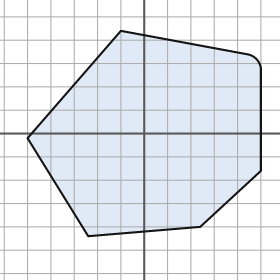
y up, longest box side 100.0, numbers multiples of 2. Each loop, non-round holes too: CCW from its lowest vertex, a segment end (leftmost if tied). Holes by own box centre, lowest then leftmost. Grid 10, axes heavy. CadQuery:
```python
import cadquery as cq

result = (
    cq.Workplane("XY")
    .moveTo(-24.0, -44.0)
    .lineTo(24.0, -40.0)
    .lineTo(50.0, -16.0)
    .lineTo(50.0, 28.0)
    .threePointArc((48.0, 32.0), (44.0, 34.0))
    .lineTo(-10.0, 44.0)
    .lineTo(-50.0, -2.0)
    .close()
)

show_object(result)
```